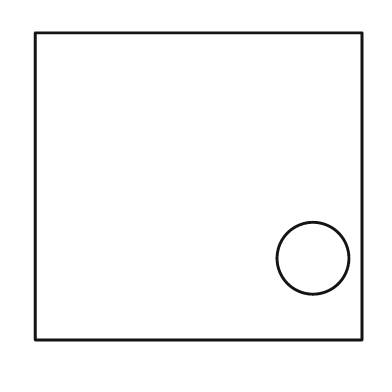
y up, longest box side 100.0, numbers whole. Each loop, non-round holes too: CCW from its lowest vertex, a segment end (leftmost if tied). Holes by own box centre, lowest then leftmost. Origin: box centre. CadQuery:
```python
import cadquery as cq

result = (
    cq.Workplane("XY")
    .moveTo(-50.0, -47.0)
    .lineTo(50.0, -47.0)
    .lineTo(50.0, 47.0)
    .lineTo(-50.0, 47.0)
    .close()
    .moveTo(35.0, -22.0)
    .circle(11.0)
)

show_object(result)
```